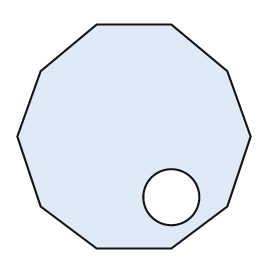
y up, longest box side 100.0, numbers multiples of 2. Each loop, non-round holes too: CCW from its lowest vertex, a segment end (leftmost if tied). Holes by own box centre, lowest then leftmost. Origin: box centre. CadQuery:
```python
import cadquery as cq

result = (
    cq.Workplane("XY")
    .moveTo(-16.0, -48.0)
    .lineTo(16.0, -48.0)
    .lineTo(40.0, -30.0)
    .lineTo(50.0, 0.0)
    .lineTo(40.0, 28.0)
    .lineTo(16.0, 48.0)
    .lineTo(-16.0, 48.0)
    .lineTo(-40.0, 28.0)
    .lineTo(-50.0, 0.0)
    .lineTo(-40.0, -30.0)
    .close()
    .moveTo(16.0, -26.0)
    .circle(12.0)
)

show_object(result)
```